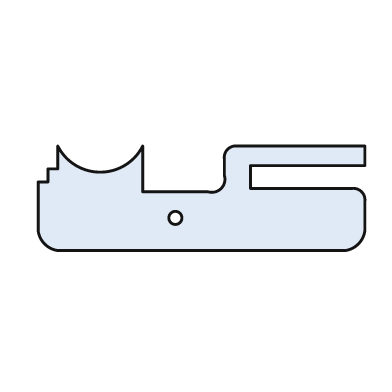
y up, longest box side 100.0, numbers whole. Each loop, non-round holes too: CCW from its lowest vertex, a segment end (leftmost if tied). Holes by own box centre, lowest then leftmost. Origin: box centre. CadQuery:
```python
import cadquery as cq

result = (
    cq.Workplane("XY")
    .moveTo(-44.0, -16.0)
    .lineTo(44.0, -16.0)
    .threePointArc((48.0, -14.0), (50.0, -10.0))
    .lineTo(50.0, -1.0)
    .threePointArc((49.0, 2.0), (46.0, 3.0))
    .lineTo(15.0, 3.0)
    .lineTo(15.0, 10.0)
    .lineTo(50.0, 10.0)
    .lineTo(50.0, 16.0)
    .lineTo(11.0, 16.0)
    .threePointArc((8.0, 15.0), (7.0, 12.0))
    .lineTo(7.0, 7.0)
    .threePointArc((6.0, 3.0), (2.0, 2.0))
    .lineTo(-18.0, 2.0)
    .lineTo(-18.0, 16.0)
    .threePointArc((-31.0, 8.0), (-44.0, 16.0))
    .lineTo(-44.0, 9.0)
    .lineTo(-47.0, 9.0)
    .lineTo(-47.0, 5.0)
    .lineTo(-50.0, 5.0)
    .lineTo(-50.0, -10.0)
    .threePointArc((-48.0, -14.0), (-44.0, -16.0))
    .close()
    .moveTo(-8.0, -6.0)
    .circle(2.0)
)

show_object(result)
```